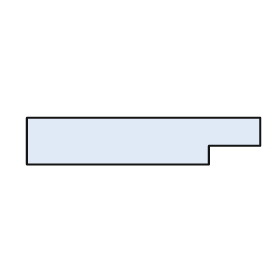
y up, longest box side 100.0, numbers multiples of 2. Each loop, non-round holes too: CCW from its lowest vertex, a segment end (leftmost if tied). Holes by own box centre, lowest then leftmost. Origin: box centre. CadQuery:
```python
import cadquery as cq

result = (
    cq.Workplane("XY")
    .moveTo(-50.0, -10.0)
    .lineTo(28.0, -10.0)
    .lineTo(28.0, -2.0)
    .lineTo(50.0, -2.0)
    .lineTo(50.0, 10.0)
    .lineTo(-50.0, 10.0)
    .close()
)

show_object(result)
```